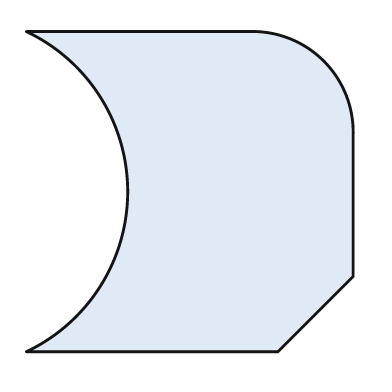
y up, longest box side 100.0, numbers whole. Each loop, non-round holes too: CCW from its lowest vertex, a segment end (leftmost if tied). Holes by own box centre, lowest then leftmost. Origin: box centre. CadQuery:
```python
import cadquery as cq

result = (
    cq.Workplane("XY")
    .moveTo(-50.0, -49.0)
    .lineTo(27.0, -49.0)
    .lineTo(50.0, -26.0)
    .lineTo(50.0, 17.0)
    .threePointArc((41.0, 40.0), (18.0, 49.0))
    .lineTo(-50.0, 49.0)
    .threePointArc((-19.0, 0.0), (-50.0, -49.0))
    .close()
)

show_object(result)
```